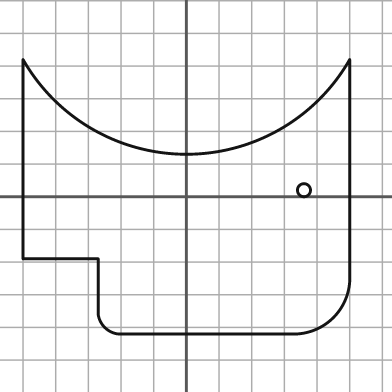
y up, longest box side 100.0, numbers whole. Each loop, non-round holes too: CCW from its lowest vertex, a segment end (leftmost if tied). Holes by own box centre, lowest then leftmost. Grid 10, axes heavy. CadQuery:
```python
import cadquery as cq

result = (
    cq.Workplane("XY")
    .moveTo(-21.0, -42.0)
    .lineTo(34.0, -42.0)
    .threePointArc((45.0, -37.0), (50.0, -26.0))
    .lineTo(50.0, 42.0)
    .threePointArc((0.0, 13.0), (-50.0, 42.0))
    .lineTo(-50.0, -19.0)
    .lineTo(-27.0, -19.0)
    .lineTo(-27.0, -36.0)
    .threePointArc((-25.0, -40.0), (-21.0, -42.0))
    .close()
    .moveTo(36.0, 2.0)
    .circle(2.0)
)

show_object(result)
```